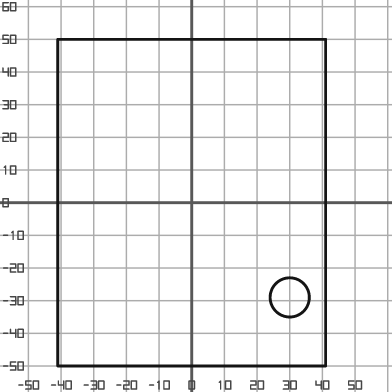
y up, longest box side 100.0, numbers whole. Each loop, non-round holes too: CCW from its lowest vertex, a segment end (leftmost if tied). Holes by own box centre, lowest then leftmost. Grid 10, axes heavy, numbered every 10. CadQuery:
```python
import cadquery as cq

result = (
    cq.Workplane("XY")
    .moveTo(-41.0, -50.0)
    .lineTo(41.0, -50.0)
    .lineTo(41.0, 50.0)
    .lineTo(-41.0, 50.0)
    .close()
    .moveTo(30.0, -29.0)
    .circle(6.0)
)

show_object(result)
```